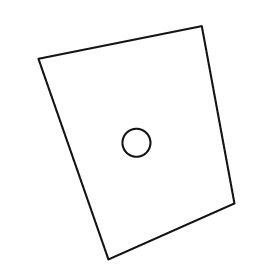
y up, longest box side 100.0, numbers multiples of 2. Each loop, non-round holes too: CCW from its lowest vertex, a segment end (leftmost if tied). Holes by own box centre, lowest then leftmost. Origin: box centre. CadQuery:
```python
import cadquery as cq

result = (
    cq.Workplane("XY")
    .moveTo(-12.0, -50.0)
    .lineTo(42.0, -26.0)
    .lineTo(28.0, 50.0)
    .lineTo(-42.0, 36.0)
    .close()
    .moveTo(0.0, 0.0)
    .circle(6.0)
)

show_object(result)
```